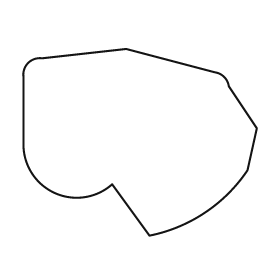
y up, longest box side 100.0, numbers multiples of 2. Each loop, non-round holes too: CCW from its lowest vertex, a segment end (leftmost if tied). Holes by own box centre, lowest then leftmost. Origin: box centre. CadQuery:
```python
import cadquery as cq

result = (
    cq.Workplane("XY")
    .moveTo(4.0, -40.0)
    .threePointArc((28.0, -30.0), (46.0, -12.0))
    .lineTo(50.0, 6.0)
    .lineTo(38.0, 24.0)
    .threePointArc((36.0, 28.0), (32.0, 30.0))
    .lineTo(-6.0, 40.0)
    .lineTo(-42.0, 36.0)
    .threePointArc((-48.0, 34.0), (-50.0, 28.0))
    .lineTo(-50.0, -2.0)
    .threePointArc((-36.0, -22.0), (-12.0, -18.0))
    .close()
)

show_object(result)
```